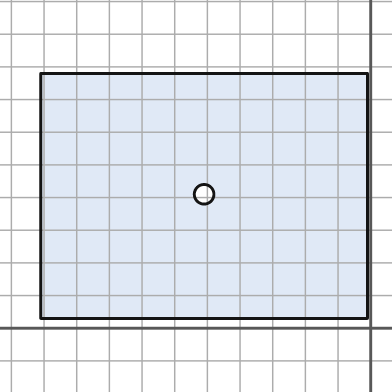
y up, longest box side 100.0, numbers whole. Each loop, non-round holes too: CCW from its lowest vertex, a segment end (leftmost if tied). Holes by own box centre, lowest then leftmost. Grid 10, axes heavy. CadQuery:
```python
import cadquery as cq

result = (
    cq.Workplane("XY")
    .moveTo(-101.0, 3.0)
    .lineTo(-1.0, 3.0)
    .lineTo(-1.0, 78.0)
    .lineTo(-101.0, 78.0)
    .close()
    .moveTo(-51.0, 41.0)
    .circle(3.0)
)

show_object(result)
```